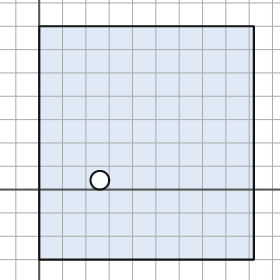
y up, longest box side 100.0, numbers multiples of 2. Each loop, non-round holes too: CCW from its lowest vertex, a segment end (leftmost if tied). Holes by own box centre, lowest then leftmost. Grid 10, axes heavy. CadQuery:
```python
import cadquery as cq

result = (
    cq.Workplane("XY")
    .moveTo(0.0, -30.0)
    .lineTo(92.0, -30.0)
    .lineTo(92.0, 70.0)
    .lineTo(0.0, 70.0)
    .close()
    .moveTo(26.0, 4.0)
    .circle(4.0)
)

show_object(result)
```